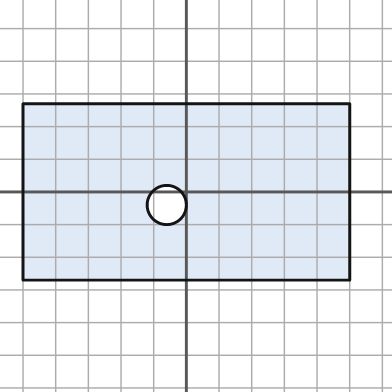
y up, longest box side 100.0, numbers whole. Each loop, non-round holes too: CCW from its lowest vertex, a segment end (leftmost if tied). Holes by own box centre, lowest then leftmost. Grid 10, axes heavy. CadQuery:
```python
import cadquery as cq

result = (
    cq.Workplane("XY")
    .moveTo(-50.0, -27.0)
    .lineTo(50.0, -27.0)
    .lineTo(50.0, 27.0)
    .lineTo(-50.0, 27.0)
    .close()
    .moveTo(-6.0, -4.0)
    .circle(6.0)
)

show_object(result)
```